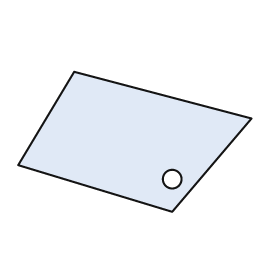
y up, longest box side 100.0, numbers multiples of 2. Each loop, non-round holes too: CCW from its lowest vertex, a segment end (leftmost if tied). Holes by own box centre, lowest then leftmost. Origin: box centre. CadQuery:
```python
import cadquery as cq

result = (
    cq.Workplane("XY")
    .moveTo(16.0, -30.0)
    .lineTo(50.0, 10.0)
    .lineTo(-26.0, 30.0)
    .lineTo(-50.0, -10.0)
    .close()
    .moveTo(16.0, -16.0)
    .circle(4.0)
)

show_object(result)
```